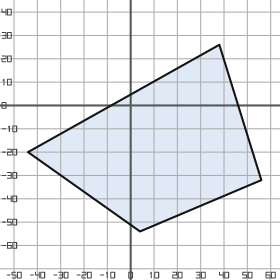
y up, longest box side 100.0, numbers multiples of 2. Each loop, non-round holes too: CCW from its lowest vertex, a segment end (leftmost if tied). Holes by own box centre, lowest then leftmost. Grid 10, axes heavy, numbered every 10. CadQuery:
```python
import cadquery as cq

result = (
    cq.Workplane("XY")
    .moveTo(4.0, -54.0)
    .lineTo(56.0, -32.0)
    .lineTo(38.0, 26.0)
    .lineTo(-44.0, -20.0)
    .close()
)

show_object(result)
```